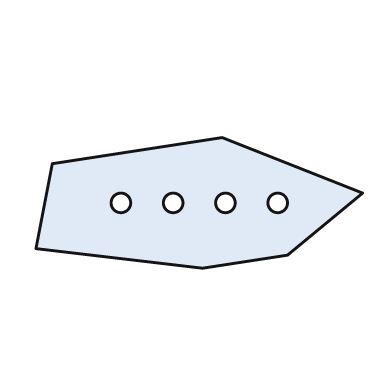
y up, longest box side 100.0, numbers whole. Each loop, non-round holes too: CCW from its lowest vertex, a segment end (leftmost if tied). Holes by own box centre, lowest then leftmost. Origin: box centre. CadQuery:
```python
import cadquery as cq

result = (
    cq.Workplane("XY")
    .moveTo(1.0, -20.0)
    .lineTo(27.0, -16.0)
    .lineTo(50.0, 3.0)
    .lineTo(7.0, 20.0)
    .lineTo(-45.0, 12.0)
    .lineTo(-50.0, -14.0)
    .close()
    .moveTo(-24.0, 0.0)
    .circle(3.0)
    .moveTo(-8.0, 0.0)
    .circle(3.0)
    .moveTo(8.0, 0.0)
    .circle(3.0)
    .moveTo(24.0, 0.0)
    .circle(3.0)
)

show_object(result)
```